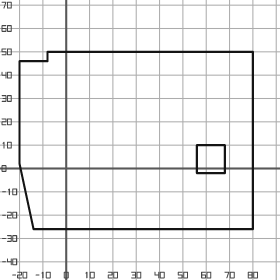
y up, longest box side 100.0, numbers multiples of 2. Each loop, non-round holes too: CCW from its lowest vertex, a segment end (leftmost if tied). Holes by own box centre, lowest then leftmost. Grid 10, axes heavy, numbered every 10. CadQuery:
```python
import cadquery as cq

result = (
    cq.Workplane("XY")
    .moveTo(-14.0, -26.0)
    .lineTo(80.0, -26.0)
    .lineTo(80.0, 50.0)
    .lineTo(-8.0, 50.0)
    .lineTo(-8.0, 46.0)
    .lineTo(-20.0, 46.0)
    .lineTo(-20.0, 2.0)
    .close()
    .moveTo(56.0, -2.0)
    .lineTo(68.0, -2.0)
    .lineTo(68.0, 10.0)
    .lineTo(56.0, 10.0)
    .close()
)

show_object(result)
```